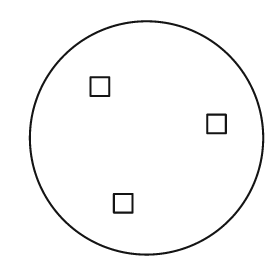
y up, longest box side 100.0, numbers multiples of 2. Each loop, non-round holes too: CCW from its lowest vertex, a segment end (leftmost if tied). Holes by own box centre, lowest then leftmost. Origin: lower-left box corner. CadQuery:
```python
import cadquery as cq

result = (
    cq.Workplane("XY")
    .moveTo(50.0, 50.0)
    .circle(50.0)
    .moveTo(36.0, 18.0)
    .lineTo(44.0, 18.0)
    .lineTo(44.0, 26.0)
    .lineTo(36.0, 26.0)
    .close()
    .moveTo(76.0, 52.0)
    .lineTo(84.0, 52.0)
    .lineTo(84.0, 60.0)
    .lineTo(76.0, 60.0)
    .close()
    .moveTo(26.0, 68.0)
    .lineTo(34.0, 68.0)
    .lineTo(34.0, 76.0)
    .lineTo(26.0, 76.0)
    .close()
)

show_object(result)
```